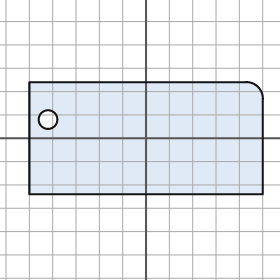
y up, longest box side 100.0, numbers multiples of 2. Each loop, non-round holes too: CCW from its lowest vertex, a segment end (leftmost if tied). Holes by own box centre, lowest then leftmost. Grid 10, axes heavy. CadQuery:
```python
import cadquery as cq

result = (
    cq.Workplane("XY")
    .moveTo(-50.0, -24.0)
    .lineTo(50.0, -24.0)
    .lineTo(50.0, 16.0)
    .threePointArc((48.0, 22.0), (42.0, 24.0))
    .lineTo(-50.0, 24.0)
    .close()
    .moveTo(-42.0, 8.0)
    .circle(4.0)
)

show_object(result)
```